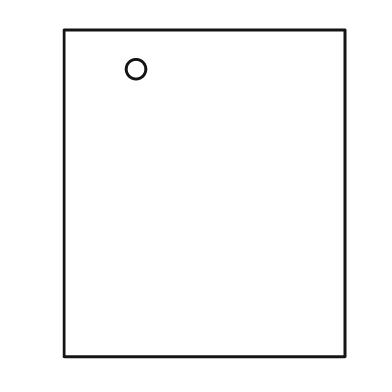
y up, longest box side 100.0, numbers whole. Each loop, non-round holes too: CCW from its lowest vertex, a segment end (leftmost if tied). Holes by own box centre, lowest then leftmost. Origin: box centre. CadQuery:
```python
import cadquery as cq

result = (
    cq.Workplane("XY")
    .moveTo(-43.0, -50.0)
    .lineTo(43.0, -50.0)
    .lineTo(43.0, 50.0)
    .lineTo(-43.0, 50.0)
    .close()
    .moveTo(-21.0, 38.0)
    .circle(3.0)
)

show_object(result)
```